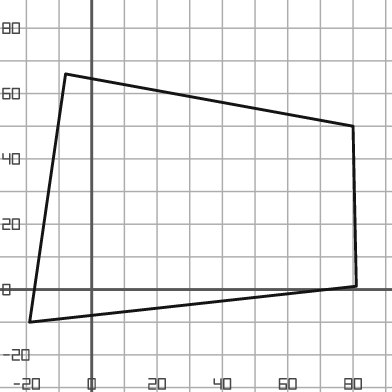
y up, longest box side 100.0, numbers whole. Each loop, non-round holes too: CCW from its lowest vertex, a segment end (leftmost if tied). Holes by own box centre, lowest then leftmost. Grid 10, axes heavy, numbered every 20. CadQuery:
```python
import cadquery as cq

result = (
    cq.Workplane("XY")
    .moveTo(-19.0, -10.0)
    .lineTo(81.0, 1.0)
    .lineTo(80.0, 50.0)
    .lineTo(-8.0, 66.0)
    .close()
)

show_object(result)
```